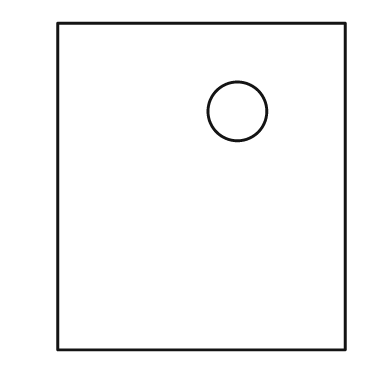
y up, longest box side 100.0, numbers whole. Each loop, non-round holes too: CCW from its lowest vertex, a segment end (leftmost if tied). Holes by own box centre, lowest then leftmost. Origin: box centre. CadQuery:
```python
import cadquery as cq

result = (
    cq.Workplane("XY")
    .moveTo(-44.0, -50.0)
    .lineTo(44.0, -50.0)
    .lineTo(44.0, 50.0)
    .lineTo(-44.0, 50.0)
    .close()
    .moveTo(11.0, 23.0)
    .circle(9.0)
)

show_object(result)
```